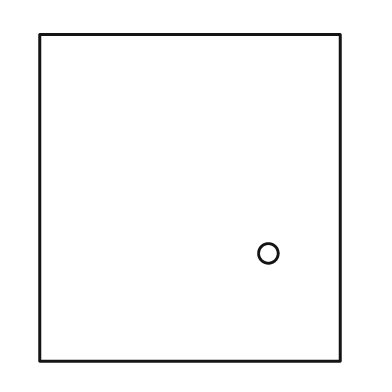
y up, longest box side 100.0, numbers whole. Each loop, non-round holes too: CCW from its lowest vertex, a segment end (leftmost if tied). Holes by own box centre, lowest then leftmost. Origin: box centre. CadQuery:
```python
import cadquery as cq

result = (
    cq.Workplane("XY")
    .moveTo(-46.0, -50.0)
    .lineTo(46.0, -50.0)
    .lineTo(46.0, 50.0)
    .lineTo(-46.0, 50.0)
    .close()
    .moveTo(24.0, -17.0)
    .circle(3.0)
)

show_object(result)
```